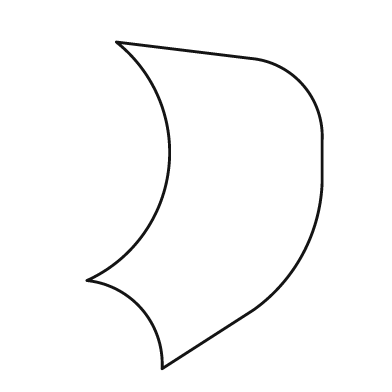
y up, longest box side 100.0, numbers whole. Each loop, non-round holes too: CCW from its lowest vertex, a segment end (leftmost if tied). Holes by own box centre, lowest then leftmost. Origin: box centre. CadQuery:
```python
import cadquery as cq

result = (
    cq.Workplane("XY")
    .moveTo(-13.0, -50.0)
    .lineTo(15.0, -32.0)
    .threePointArc((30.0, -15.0), (36.0, 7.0))
    .lineTo(36.0, 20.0)
    .threePointArc((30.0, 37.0), (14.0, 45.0))
    .lineTo(-27.0, 50.0)
    .threePointArc((-11.0, 11.0), (-36.0, -23.0))
    .threePointArc((-19.0, -32.0), (-13.0, -50.0))
    .close()
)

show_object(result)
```